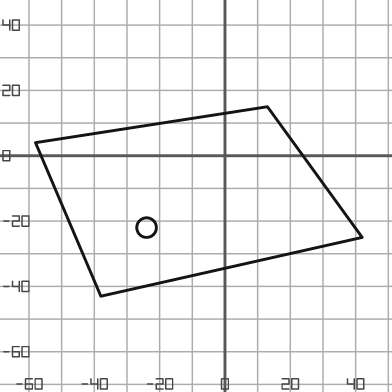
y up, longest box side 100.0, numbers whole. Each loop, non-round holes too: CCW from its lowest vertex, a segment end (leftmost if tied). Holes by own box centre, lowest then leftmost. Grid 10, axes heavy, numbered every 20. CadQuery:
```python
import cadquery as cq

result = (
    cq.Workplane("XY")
    .moveTo(-38.0, -43.0)
    .lineTo(42.0, -25.0)
    .lineTo(13.0, 15.0)
    .lineTo(-58.0, 4.0)
    .close()
    .moveTo(-24.0, -22.0)
    .circle(3.0)
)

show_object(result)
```